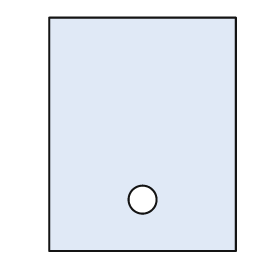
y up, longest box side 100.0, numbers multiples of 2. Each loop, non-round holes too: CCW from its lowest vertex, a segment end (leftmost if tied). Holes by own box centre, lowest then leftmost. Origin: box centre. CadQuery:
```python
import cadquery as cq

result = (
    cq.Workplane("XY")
    .moveTo(-40.0, -50.0)
    .lineTo(40.0, -50.0)
    .lineTo(40.0, 50.0)
    .lineTo(-40.0, 50.0)
    .close()
    .moveTo(0.0, -28.0)
    .circle(6.0)
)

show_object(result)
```